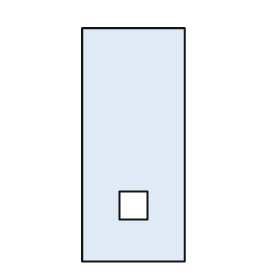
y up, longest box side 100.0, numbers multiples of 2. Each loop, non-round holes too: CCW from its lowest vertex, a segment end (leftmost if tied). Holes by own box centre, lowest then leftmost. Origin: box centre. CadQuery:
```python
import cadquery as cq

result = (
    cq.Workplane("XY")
    .moveTo(-22.0, -50.0)
    .lineTo(22.0, -50.0)
    .lineTo(22.0, 50.0)
    .lineTo(-22.0, 50.0)
    .close()
    .moveTo(-6.0, -32.0)
    .lineTo(6.0, -32.0)
    .lineTo(6.0, -20.0)
    .lineTo(-6.0, -20.0)
    .close()
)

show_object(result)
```